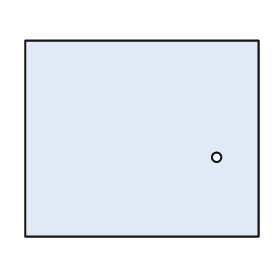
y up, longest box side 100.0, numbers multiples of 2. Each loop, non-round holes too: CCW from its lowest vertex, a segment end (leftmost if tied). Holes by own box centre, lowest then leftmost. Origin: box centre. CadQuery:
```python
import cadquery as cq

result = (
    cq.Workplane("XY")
    .moveTo(-50.0, -42.0)
    .lineTo(50.0, -42.0)
    .lineTo(50.0, 42.0)
    .lineTo(-50.0, 42.0)
    .close()
    .moveTo(32.0, -8.0)
    .circle(2.0)
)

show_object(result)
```